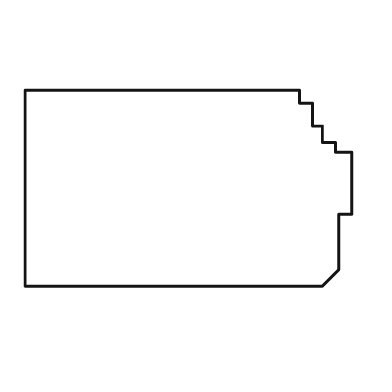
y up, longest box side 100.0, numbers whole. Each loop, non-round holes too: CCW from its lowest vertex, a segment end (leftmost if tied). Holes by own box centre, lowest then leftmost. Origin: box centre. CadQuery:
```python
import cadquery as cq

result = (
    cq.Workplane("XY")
    .moveTo(-50.0, -30.0)
    .lineTo(41.0, -30.0)
    .lineTo(46.0, -25.0)
    .lineTo(46.0, -8.0)
    .lineTo(50.0, -8.0)
    .lineTo(50.0, 11.0)
    .lineTo(45.0, 11.0)
    .lineTo(45.0, 14.0)
    .lineTo(41.0, 14.0)
    .lineTo(41.0, 19.0)
    .lineTo(38.0, 19.0)
    .lineTo(38.0, 26.0)
    .lineTo(34.0, 26.0)
    .lineTo(34.0, 30.0)
    .lineTo(-50.0, 30.0)
    .close()
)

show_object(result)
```